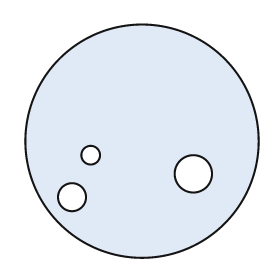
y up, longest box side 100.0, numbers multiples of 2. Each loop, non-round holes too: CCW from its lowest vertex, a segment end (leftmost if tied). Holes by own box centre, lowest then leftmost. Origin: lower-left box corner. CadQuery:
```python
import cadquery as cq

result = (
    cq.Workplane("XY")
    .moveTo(50.0, 50.0)
    .circle(50.0)
    .moveTo(20.0, 26.0)
    .circle(6.0)
    .moveTo(72.0, 36.0)
    .circle(8.0)
    .moveTo(28.0, 44.0)
    .circle(4.0)
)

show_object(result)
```